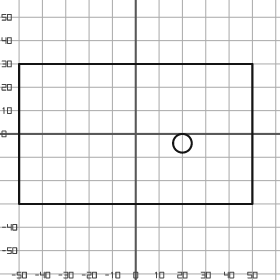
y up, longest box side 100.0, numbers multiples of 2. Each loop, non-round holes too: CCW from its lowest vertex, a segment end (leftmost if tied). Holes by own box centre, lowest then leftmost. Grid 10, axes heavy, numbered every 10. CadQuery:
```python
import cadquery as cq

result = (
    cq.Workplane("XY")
    .moveTo(-50.0, -30.0)
    .lineTo(50.0, -30.0)
    .lineTo(50.0, 30.0)
    .lineTo(-50.0, 30.0)
    .close()
    .moveTo(20.0, -4.0)
    .circle(4.0)
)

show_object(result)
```